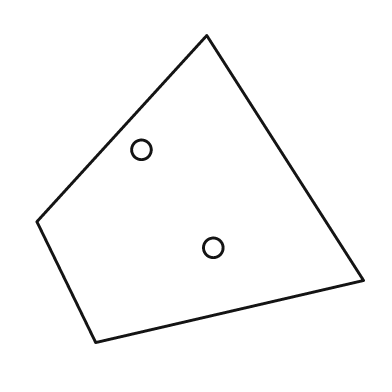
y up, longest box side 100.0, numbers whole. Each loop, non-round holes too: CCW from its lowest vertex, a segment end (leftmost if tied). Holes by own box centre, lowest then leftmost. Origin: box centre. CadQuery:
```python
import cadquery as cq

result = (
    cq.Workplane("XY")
    .moveTo(-32.0, -47.0)
    .lineTo(50.0, -28.0)
    .lineTo(2.0, 47.0)
    .lineTo(-50.0, -10.0)
    .close()
    .moveTo(4.0, -18.0)
    .circle(3.0)
    .moveTo(-18.0, 12.0)
    .circle(3.0)
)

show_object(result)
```